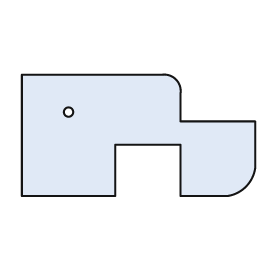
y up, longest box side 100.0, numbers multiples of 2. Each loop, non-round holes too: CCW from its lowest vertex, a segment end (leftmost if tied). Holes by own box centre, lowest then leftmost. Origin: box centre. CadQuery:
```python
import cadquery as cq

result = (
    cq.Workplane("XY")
    .moveTo(-50.0, -26.0)
    .lineTo(-10.0, -26.0)
    .lineTo(-10.0, -4.0)
    .lineTo(18.0, -4.0)
    .lineTo(18.0, -26.0)
    .lineTo(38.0, -26.0)
    .threePointArc((46.0, -22.0), (50.0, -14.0))
    .lineTo(50.0, 6.0)
    .lineTo(18.0, 6.0)
    .lineTo(18.0, 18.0)
    .threePointArc((16.0, 24.0), (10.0, 26.0))
    .lineTo(-50.0, 26.0)
    .close()
    .moveTo(-30.0, 10.0)
    .circle(2.0)
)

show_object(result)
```